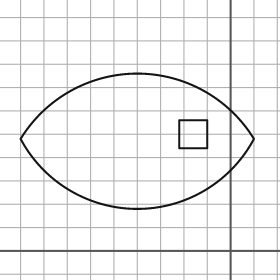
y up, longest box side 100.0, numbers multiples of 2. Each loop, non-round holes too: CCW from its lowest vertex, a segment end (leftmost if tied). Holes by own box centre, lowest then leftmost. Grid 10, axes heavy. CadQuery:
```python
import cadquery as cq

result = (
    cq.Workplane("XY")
    .moveTo(-90.0, 48.0)
    .threePointArc((-40.0, 18.0), (10.0, 48.0))
    .threePointArc((-40.0, 76.0), (-90.0, 48.0))
    .close()
    .moveTo(-22.0, 44.0)
    .lineTo(-10.0, 44.0)
    .lineTo(-10.0, 56.0)
    .lineTo(-22.0, 56.0)
    .close()
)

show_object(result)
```